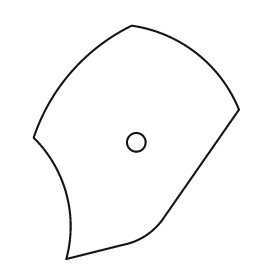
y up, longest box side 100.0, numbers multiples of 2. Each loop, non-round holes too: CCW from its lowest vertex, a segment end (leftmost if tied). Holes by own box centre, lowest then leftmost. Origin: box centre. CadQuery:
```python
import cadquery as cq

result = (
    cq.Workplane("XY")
    .moveTo(-30.0, -50.0)
    .lineTo(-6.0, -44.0)
    .threePointArc((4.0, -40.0), (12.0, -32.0))
    .lineTo(44.0, 14.0)
    .threePointArc((26.0, 38.0), (-2.0, 50.0))
    .threePointArc((-28.0, 30.0), (-44.0, 2.0))
    .threePointArc((-30.0, -22.0), (-30.0, -50.0))
    .close()
    .moveTo(0.0, 0.0)
    .circle(4.0)
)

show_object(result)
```